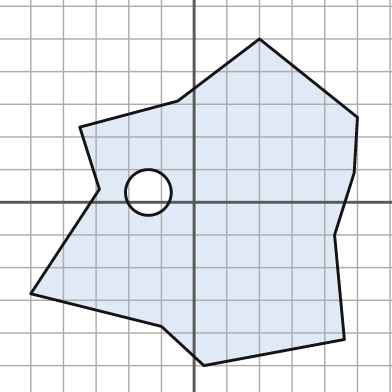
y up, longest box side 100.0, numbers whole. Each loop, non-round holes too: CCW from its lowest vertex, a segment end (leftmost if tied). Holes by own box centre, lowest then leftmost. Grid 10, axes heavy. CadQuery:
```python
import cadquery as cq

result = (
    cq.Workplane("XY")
    .moveTo(3.0, -50.0)
    .lineTo(46.0, -42.0)
    .lineTo(43.0, -10.0)
    .lineTo(49.0, 9.0)
    .lineTo(50.0, 26.0)
    .lineTo(20.0, 50.0)
    .lineTo(-5.0, 31.0)
    .lineTo(-35.0, 23.0)
    .lineTo(-29.0, 4.0)
    .lineTo(-50.0, -28.0)
    .lineTo(-10.0, -38.0)
    .close()
    .moveTo(-14.0, 3.0)
    .circle(7.0)
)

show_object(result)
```